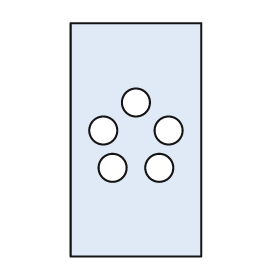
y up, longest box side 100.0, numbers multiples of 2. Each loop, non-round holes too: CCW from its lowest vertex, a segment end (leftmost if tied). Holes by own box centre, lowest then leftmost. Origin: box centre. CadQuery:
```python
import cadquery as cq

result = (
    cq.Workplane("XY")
    .moveTo(-28.0, -50.0)
    .lineTo(28.0, -50.0)
    .lineTo(28.0, 50.0)
    .lineTo(-28.0, 50.0)
    .close()
    .moveTo(-10.0, -12.0)
    .circle(6.0)
    .moveTo(10.0, -12.0)
    .circle(6.0)
    .moveTo(-14.0, 4.0)
    .circle(6.0)
    .moveTo(14.0, 4.0)
    .circle(6.0)
    .moveTo(0.0, 16.0)
    .circle(6.0)
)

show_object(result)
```